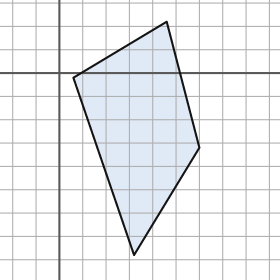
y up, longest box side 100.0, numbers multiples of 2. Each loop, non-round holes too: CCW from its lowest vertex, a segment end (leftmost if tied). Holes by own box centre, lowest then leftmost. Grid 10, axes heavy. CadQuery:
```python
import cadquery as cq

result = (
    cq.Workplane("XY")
    .moveTo(32.0, -78.0)
    .lineTo(60.0, -32.0)
    .lineTo(46.0, 22.0)
    .lineTo(6.0, -2.0)
    .close()
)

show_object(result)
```